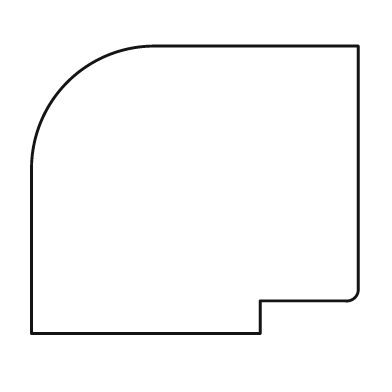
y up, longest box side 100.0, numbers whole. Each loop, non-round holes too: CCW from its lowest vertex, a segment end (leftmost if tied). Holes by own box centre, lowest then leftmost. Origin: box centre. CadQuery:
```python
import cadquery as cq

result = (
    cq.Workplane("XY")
    .moveTo(-50.0, -44.0)
    .lineTo(20.0, -44.0)
    .lineTo(20.0, -34.0)
    .lineTo(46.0, -34.0)
    .threePointArc((49.0, -33.0), (50.0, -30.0))
    .lineTo(50.0, 44.0)
    .lineTo(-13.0, 44.0)
    .threePointArc((-39.0, 33.0), (-50.0, 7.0))
    .close()
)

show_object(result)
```